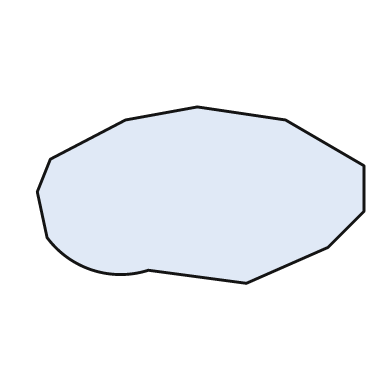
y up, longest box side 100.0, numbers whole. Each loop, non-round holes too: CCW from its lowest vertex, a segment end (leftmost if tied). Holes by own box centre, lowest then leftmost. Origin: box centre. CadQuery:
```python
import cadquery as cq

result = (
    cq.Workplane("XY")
    .moveTo(14.0, -27.0)
    .lineTo(39.0, -16.0)
    .lineTo(50.0, -5.0)
    .lineTo(50.0, 9.0)
    .lineTo(26.0, 23.0)
    .lineTo(-1.0, 27.0)
    .lineTo(-23.0, 23.0)
    .lineTo(-46.0, 11.0)
    .lineTo(-50.0, 1.0)
    .lineTo(-47.0, -13.0)
    .threePointArc((-33.0, -23.0), (-16.0, -23.0))
    .close()
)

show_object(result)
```